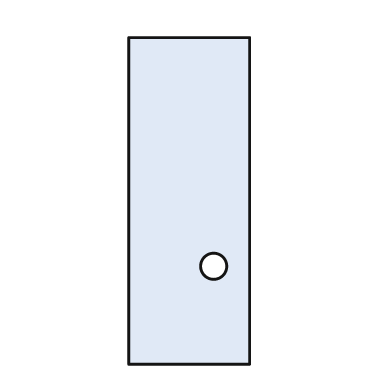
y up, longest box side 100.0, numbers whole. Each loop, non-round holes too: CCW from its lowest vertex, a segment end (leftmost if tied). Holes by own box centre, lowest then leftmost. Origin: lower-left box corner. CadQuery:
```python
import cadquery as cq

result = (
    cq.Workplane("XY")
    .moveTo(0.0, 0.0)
    .lineTo(37.0, 0.0)
    .lineTo(37.0, 100.0)
    .lineTo(0.0, 100.0)
    .close()
    .moveTo(26.0, 30.0)
    .circle(4.0)
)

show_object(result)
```